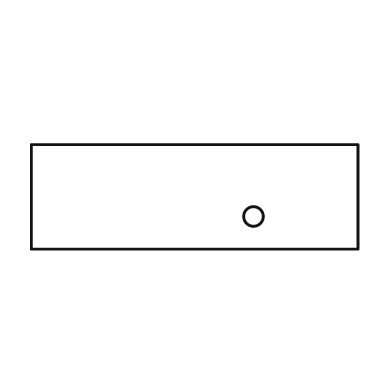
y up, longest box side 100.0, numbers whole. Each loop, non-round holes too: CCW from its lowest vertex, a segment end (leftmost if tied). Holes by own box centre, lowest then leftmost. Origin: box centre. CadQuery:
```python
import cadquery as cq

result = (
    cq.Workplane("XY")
    .moveTo(-50.0, -16.0)
    .lineTo(50.0, -16.0)
    .lineTo(50.0, 16.0)
    .lineTo(-50.0, 16.0)
    .close()
    .moveTo(18.0, -6.0)
    .circle(3.0)
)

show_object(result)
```